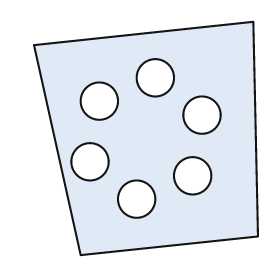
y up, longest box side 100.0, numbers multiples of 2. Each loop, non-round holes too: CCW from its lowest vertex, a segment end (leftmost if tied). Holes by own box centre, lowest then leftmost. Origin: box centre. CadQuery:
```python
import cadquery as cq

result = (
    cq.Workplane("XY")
    .moveTo(-28.0, -50.0)
    .lineTo(48.0, -42.0)
    .lineTo(46.0, 50.0)
    .lineTo(-48.0, 40.0)
    .close()
    .moveTo(-4.0, -26.0)
    .circle(8.0)
    .moveTo(20.0, -16.0)
    .circle(8.0)
    .moveTo(-24.0, -10.0)
    .circle(8.0)
    .moveTo(24.0, 10.0)
    .circle(8.0)
    .moveTo(-20.0, 16.0)
    .circle(8.0)
    .moveTo(4.0, 26.0)
    .circle(8.0)
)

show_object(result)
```